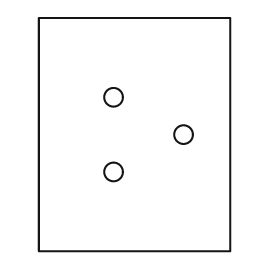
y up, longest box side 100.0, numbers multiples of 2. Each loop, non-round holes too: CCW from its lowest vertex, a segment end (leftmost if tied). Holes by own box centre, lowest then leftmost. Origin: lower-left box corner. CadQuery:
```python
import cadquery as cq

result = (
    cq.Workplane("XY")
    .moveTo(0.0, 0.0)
    .lineTo(82.0, 0.0)
    .lineTo(82.0, 100.0)
    .lineTo(0.0, 100.0)
    .close()
    .moveTo(32.0, 34.0)
    .circle(4.0)
    .moveTo(62.0, 50.0)
    .circle(4.0)
    .moveTo(32.0, 66.0)
    .circle(4.0)
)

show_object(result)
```